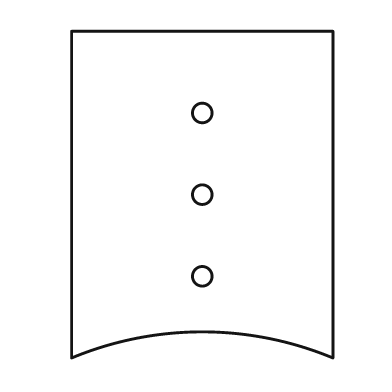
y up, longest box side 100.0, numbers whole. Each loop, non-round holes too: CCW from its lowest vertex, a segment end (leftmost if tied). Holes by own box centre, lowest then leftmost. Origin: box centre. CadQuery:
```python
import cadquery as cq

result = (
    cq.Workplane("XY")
    .moveTo(-40.0, -50.0)
    .threePointArc((0.0, -42.0), (40.0, -50.0))
    .lineTo(40.0, 50.0)
    .lineTo(-40.0, 50.0)
    .close()
    .moveTo(0.0, -25.0)
    .circle(3.0)
    .moveTo(0.0, 0.0)
    .circle(3.0)
    .moveTo(0.0, 25.0)
    .circle(3.0)
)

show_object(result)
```